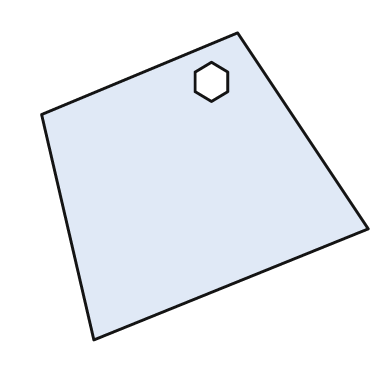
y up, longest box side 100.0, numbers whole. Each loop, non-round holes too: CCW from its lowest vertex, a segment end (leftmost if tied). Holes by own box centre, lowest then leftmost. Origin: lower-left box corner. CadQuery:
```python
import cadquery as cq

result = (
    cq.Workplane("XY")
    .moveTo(16.0, 0.0)
    .lineTo(100.0, 34.0)
    .lineTo(60.0, 94.0)
    .lineTo(0.0, 69.0)
    .close()
    .moveTo(52.0, 73.0)
    .lineTo(57.0, 76.0)
    .lineTo(57.0, 82.0)
    .lineTo(52.0, 85.0)
    .lineTo(47.0, 82.0)
    .lineTo(47.0, 76.0)
    .close()
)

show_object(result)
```